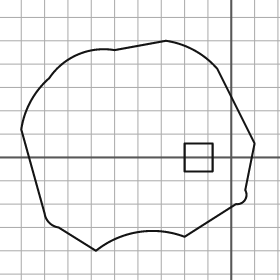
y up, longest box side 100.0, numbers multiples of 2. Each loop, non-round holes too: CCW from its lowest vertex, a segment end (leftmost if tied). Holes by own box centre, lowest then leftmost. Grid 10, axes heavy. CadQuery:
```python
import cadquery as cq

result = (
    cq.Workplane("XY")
    .moveTo(-58.0, -40.0)
    .threePointArc((-40.0, -32.0), (-20.0, -34.0))
    .lineTo(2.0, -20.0)
    .threePointArc((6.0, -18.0), (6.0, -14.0))
    .lineTo(10.0, 6.0)
    .lineTo(-6.0, 38.0)
    .threePointArc((-16.0, 46.0), (-28.0, 50.0))
    .lineTo(-50.0, 46.0)
    .threePointArc((-66.0, 44.0), (-78.0, 34.0))
    .threePointArc((-86.0, 24.0), (-90.0, 12.0))
    .lineTo(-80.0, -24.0)
    .threePointArc((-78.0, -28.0), (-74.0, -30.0))
    .close()
    .moveTo(-20.0, -6.0)
    .lineTo(-8.0, -6.0)
    .lineTo(-8.0, 6.0)
    .lineTo(-20.0, 6.0)
    .close()
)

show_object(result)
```